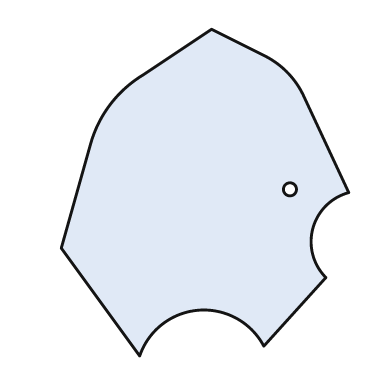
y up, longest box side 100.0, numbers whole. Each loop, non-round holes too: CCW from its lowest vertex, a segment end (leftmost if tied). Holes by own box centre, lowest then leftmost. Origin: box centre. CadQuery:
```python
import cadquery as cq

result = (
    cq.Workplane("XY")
    .moveTo(-20.0, -50.0)
    .threePointArc((-2.0, -36.0), (18.0, -47.0))
    .lineTo(37.0, -26.0)
    .threePointArc((33.0, -11.0), (44.0, 0.0))
    .lineTo(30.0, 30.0)
    .threePointArc((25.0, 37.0), (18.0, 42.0))
    .lineTo(2.0, 50.0)
    .lineTo(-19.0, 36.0)
    .threePointArc((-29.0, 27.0), (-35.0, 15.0))
    .lineTo(-44.0, -17.0)
    .close()
    .moveTo(26.0, 1.0)
    .circle(2.0)
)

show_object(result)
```